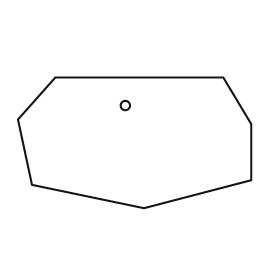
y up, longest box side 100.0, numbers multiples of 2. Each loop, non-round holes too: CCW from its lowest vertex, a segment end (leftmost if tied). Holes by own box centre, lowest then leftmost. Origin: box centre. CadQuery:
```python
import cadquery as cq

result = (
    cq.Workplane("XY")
    .moveTo(4.0, -28.0)
    .lineTo(50.0, -16.0)
    .lineTo(50.0, 8.0)
    .lineTo(38.0, 28.0)
    .lineTo(-34.0, 28.0)
    .lineTo(-50.0, 10.0)
    .lineTo(-44.0, -18.0)
    .close()
    .moveTo(-4.0, 16.0)
    .circle(2.0)
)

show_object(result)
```